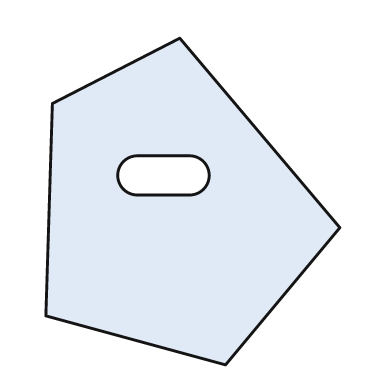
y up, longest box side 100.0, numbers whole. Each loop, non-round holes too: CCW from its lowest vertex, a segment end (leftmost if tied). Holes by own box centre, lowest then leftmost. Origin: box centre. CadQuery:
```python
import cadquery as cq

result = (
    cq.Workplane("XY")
    .moveTo(10.0, -50.0)
    .lineTo(45.0, -8.0)
    .lineTo(-4.0, 50.0)
    .lineTo(-43.0, 30.0)
    .lineTo(-45.0, -35.0)
    .close()
    .moveTo(-17.0, 2.0)
    .lineTo(-1.0, 2.0)
    .threePointArc((5.0, 8.0), (-1.0, 14.0))
    .lineTo(-17.0, 14.0)
    .threePointArc((-23.0, 8.0), (-17.0, 2.0))
    .close()
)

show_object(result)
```